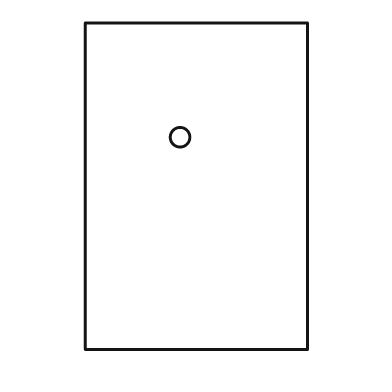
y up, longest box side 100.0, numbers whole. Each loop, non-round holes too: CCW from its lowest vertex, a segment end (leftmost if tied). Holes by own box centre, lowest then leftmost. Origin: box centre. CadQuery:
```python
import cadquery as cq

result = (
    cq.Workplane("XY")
    .moveTo(-34.0, -50.0)
    .lineTo(34.0, -50.0)
    .lineTo(34.0, 50.0)
    .lineTo(-34.0, 50.0)
    .close()
    .moveTo(-5.0, 15.0)
    .circle(3.0)
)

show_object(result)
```